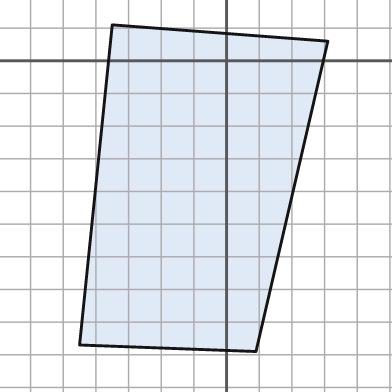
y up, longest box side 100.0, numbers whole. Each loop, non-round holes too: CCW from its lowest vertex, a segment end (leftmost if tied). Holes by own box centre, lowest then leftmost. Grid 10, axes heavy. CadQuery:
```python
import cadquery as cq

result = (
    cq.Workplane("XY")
    .moveTo(9.0, -89.0)
    .lineTo(31.0, 6.0)
    .lineTo(-35.0, 11.0)
    .lineTo(-45.0, -87.0)
    .close()
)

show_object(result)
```